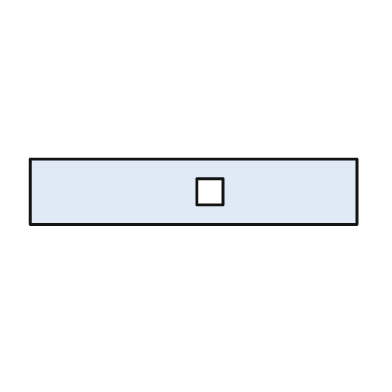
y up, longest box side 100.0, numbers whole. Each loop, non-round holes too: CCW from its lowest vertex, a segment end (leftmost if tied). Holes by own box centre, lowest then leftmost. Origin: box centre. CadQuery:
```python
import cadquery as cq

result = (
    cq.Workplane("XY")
    .moveTo(-50.0, -10.0)
    .lineTo(50.0, -10.0)
    .lineTo(50.0, 10.0)
    .lineTo(-50.0, 10.0)
    .close()
    .moveTo(1.0, -4.0)
    .lineTo(9.0, -4.0)
    .lineTo(9.0, 4.0)
    .lineTo(1.0, 4.0)
    .close()
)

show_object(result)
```